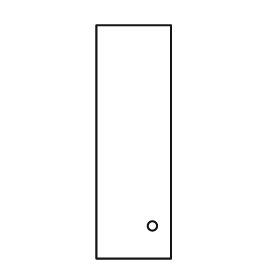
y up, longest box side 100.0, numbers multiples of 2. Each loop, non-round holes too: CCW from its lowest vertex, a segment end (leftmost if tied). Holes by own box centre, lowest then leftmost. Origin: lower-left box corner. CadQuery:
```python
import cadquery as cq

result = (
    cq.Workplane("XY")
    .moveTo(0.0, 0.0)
    .lineTo(32.0, 0.0)
    .lineTo(32.0, 100.0)
    .lineTo(0.0, 100.0)
    .close()
    .moveTo(24.0, 14.0)
    .circle(2.0)
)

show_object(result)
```